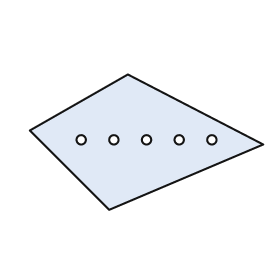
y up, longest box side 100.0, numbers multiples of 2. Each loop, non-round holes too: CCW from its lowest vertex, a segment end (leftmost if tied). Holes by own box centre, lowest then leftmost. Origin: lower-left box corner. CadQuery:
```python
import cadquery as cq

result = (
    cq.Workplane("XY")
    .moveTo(34.0, 0.0)
    .lineTo(100.0, 28.0)
    .lineTo(42.0, 58.0)
    .lineTo(0.0, 34.0)
    .close()
    .moveTo(22.0, 30.0)
    .circle(2.0)
    .moveTo(36.0, 30.0)
    .circle(2.0)
    .moveTo(50.0, 30.0)
    .circle(2.0)
    .moveTo(64.0, 30.0)
    .circle(2.0)
    .moveTo(78.0, 30.0)
    .circle(2.0)
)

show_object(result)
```